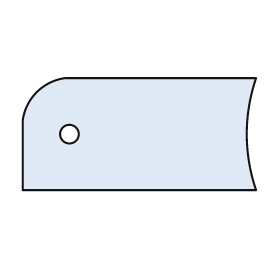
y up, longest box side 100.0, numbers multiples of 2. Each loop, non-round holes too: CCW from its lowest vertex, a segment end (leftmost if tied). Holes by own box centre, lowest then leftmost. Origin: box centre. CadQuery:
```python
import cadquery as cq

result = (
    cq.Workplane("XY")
    .moveTo(-50.0, -24.0)
    .lineTo(50.0, -24.0)
    .threePointArc((46.0, 0.0), (50.0, 24.0))
    .lineTo(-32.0, 24.0)
    .threePointArc((-44.0, 18.0), (-50.0, 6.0))
    .close()
    .moveTo(-30.0, 0.0)
    .circle(4.0)
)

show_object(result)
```